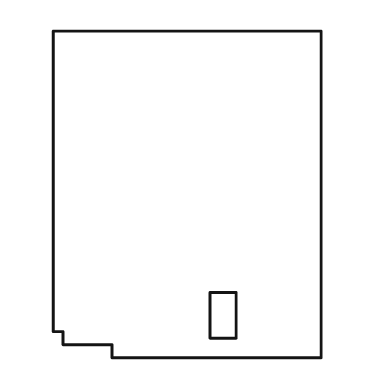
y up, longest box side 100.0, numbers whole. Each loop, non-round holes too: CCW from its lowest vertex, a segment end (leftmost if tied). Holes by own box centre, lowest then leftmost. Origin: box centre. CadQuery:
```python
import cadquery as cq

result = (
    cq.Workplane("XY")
    .moveTo(-23.0, -50.0)
    .lineTo(41.0, -50.0)
    .lineTo(41.0, 50.0)
    .lineTo(-41.0, 50.0)
    .lineTo(-41.0, -42.0)
    .lineTo(-38.0, -42.0)
    .lineTo(-38.0, -46.0)
    .lineTo(-23.0, -46.0)
    .close()
    .moveTo(7.0, -44.0)
    .lineTo(15.0, -44.0)
    .lineTo(15.0, -30.0)
    .lineTo(7.0, -30.0)
    .close()
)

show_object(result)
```